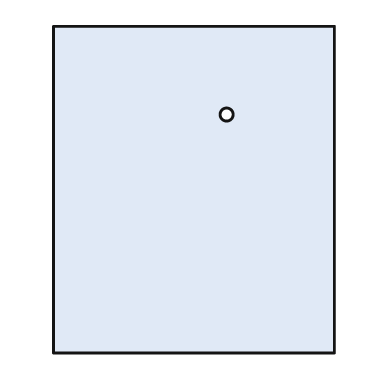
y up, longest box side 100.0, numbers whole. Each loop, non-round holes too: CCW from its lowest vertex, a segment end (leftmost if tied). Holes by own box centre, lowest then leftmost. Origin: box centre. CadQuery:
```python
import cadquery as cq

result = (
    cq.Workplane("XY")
    .moveTo(-43.0, -50.0)
    .lineTo(43.0, -50.0)
    .lineTo(43.0, 50.0)
    .lineTo(-43.0, 50.0)
    .close()
    .moveTo(10.0, 23.0)
    .circle(2.0)
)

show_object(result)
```